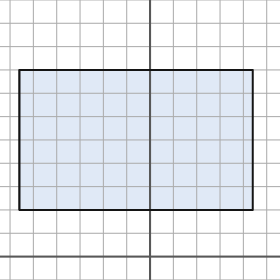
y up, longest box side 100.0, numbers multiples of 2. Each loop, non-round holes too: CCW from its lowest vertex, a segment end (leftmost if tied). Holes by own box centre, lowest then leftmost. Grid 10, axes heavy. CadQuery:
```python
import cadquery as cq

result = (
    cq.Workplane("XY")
    .moveTo(-56.0, 20.0)
    .lineTo(44.0, 20.0)
    .lineTo(44.0, 80.0)
    .lineTo(-56.0, 80.0)
    .close()
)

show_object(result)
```